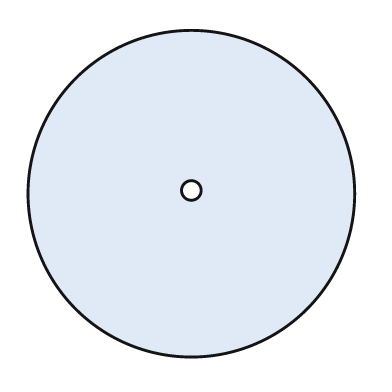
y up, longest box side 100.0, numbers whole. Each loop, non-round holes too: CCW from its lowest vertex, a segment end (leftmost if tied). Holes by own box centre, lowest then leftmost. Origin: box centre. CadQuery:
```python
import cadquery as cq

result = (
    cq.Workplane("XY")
    .moveTo(0.0, 0.0)
    .circle(50.0)
    .moveTo(0.0, 1.0)
    .circle(3.0)
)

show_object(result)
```